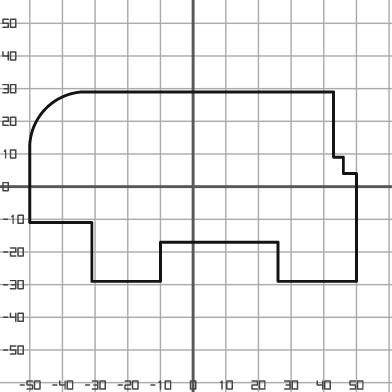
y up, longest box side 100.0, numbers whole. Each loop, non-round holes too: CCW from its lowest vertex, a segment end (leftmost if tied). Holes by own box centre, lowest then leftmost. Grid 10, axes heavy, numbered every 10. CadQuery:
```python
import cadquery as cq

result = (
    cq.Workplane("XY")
    .moveTo(-31.0, -29.0)
    .lineTo(-10.0, -29.0)
    .lineTo(-10.0, -17.0)
    .lineTo(26.0, -17.0)
    .lineTo(26.0, -29.0)
    .lineTo(50.0, -29.0)
    .lineTo(50.0, 4.0)
    .lineTo(46.0, 4.0)
    .lineTo(46.0, 9.0)
    .lineTo(43.0, 9.0)
    .lineTo(43.0, 29.0)
    .lineTo(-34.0, 29.0)
    .threePointArc((-45.0, 24.0), (-50.0, 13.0))
    .lineTo(-50.0, -11.0)
    .lineTo(-31.0, -11.0)
    .close()
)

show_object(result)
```